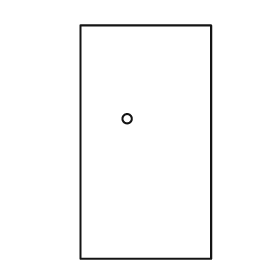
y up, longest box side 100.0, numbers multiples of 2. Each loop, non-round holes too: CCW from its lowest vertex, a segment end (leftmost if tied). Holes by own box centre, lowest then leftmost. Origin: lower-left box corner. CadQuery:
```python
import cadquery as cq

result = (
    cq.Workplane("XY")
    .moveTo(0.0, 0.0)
    .lineTo(56.0, 0.0)
    .lineTo(56.0, 100.0)
    .lineTo(0.0, 100.0)
    .close()
    .moveTo(20.0, 60.0)
    .circle(2.0)
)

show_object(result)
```